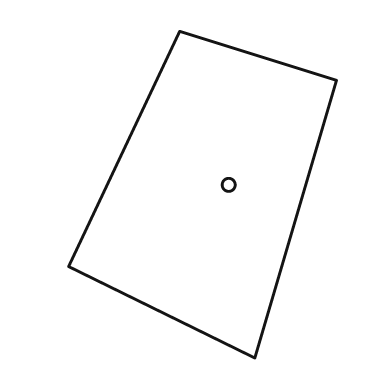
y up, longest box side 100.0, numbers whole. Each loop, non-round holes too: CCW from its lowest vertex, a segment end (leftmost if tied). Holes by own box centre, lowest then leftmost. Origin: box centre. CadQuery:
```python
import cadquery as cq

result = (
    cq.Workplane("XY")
    .moveTo(16.0, -50.0)
    .lineTo(41.0, 35.0)
    .lineTo(-7.0, 50.0)
    .lineTo(-41.0, -22.0)
    .close()
    .moveTo(8.0, 3.0)
    .circle(2.0)
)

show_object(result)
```